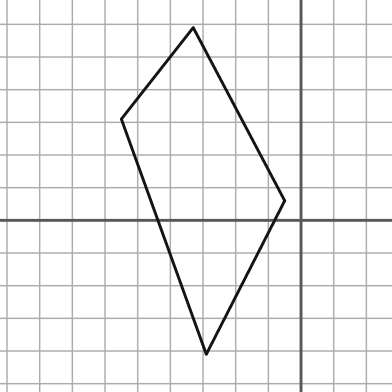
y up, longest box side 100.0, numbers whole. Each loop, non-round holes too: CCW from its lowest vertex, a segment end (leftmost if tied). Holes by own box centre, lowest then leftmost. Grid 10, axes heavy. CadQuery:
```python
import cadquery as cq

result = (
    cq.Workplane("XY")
    .moveTo(-29.0, -41.0)
    .lineTo(-5.0, 6.0)
    .lineTo(-33.0, 59.0)
    .lineTo(-55.0, 31.0)
    .close()
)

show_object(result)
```